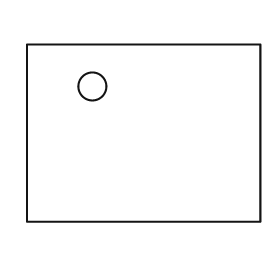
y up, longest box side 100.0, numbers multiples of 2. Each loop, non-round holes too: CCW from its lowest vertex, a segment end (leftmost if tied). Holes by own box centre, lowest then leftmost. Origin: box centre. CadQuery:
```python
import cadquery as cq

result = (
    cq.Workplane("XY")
    .moveTo(-50.0, -38.0)
    .lineTo(50.0, -38.0)
    .lineTo(50.0, 38.0)
    .lineTo(-50.0, 38.0)
    .close()
    .moveTo(-22.0, 20.0)
    .circle(6.0)
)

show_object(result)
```